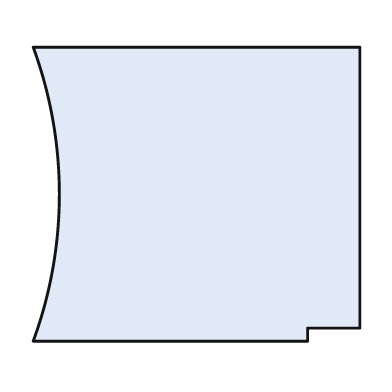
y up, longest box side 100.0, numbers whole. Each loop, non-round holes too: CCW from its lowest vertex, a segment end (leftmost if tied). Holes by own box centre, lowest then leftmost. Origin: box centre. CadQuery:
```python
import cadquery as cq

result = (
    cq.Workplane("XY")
    .moveTo(-50.0, -45.0)
    .lineTo(34.0, -45.0)
    .lineTo(34.0, -41.0)
    .lineTo(50.0, -41.0)
    .lineTo(50.0, 45.0)
    .lineTo(-50.0, 45.0)
    .threePointArc((-42.0, 0.0), (-50.0, -45.0))
    .close()
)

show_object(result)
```